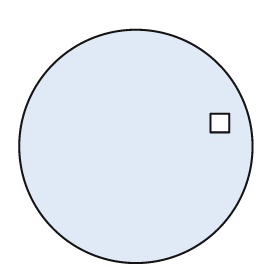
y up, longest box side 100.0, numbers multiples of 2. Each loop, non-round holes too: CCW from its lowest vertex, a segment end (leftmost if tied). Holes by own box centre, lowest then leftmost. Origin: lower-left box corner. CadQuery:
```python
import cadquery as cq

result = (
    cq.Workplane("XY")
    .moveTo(50.0, 50.0)
    .circle(50.0)
    .moveTo(82.0, 56.0)
    .lineTo(90.0, 56.0)
    .lineTo(90.0, 64.0)
    .lineTo(82.0, 64.0)
    .close()
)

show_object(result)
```